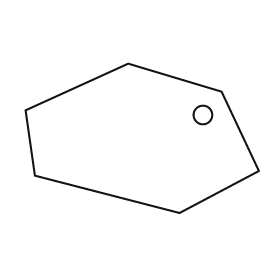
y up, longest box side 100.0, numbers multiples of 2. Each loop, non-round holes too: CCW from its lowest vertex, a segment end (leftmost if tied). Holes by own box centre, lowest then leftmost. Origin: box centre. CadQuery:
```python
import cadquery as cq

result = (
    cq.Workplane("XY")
    .moveTo(16.0, -32.0)
    .lineTo(50.0, -14.0)
    .lineTo(34.0, 20.0)
    .lineTo(-6.0, 32.0)
    .lineTo(-50.0, 12.0)
    .lineTo(-46.0, -16.0)
    .close()
    .moveTo(26.0, 10.0)
    .circle(4.0)
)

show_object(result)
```